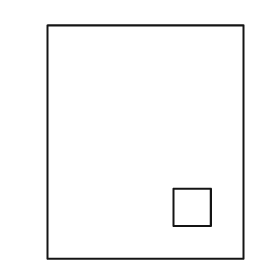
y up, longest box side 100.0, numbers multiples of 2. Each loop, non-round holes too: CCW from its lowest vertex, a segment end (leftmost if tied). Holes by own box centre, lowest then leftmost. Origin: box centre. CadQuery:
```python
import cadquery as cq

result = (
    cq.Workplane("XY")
    .moveTo(-42.0, -50.0)
    .lineTo(42.0, -50.0)
    .lineTo(42.0, 50.0)
    .lineTo(-42.0, 50.0)
    .close()
    .moveTo(12.0, -36.0)
    .lineTo(28.0, -36.0)
    .lineTo(28.0, -20.0)
    .lineTo(12.0, -20.0)
    .close()
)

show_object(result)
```